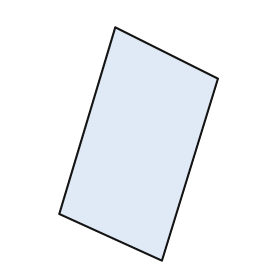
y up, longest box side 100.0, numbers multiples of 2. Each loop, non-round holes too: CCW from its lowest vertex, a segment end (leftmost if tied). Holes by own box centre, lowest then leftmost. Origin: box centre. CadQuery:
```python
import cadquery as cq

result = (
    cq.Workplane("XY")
    .moveTo(10.0, -50.0)
    .lineTo(34.0, 28.0)
    .lineTo(-10.0, 50.0)
    .lineTo(-34.0, -30.0)
    .close()
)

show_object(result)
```